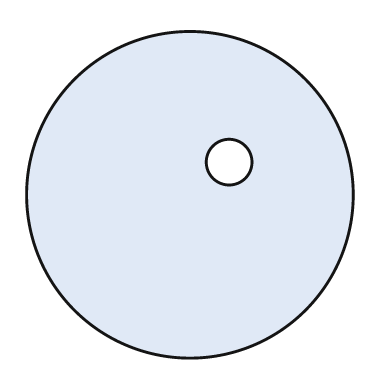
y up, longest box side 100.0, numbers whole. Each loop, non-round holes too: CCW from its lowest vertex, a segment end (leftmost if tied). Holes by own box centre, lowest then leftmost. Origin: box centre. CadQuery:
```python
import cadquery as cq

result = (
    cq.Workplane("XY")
    .moveTo(0.0, 0.0)
    .circle(50.0)
    .moveTo(12.0, 10.0)
    .circle(7.0)
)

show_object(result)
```